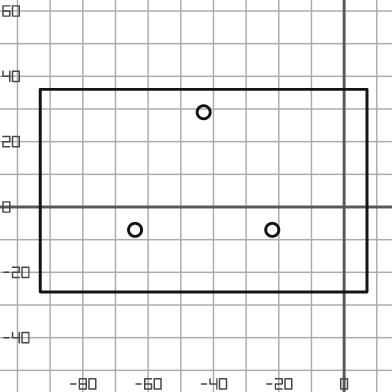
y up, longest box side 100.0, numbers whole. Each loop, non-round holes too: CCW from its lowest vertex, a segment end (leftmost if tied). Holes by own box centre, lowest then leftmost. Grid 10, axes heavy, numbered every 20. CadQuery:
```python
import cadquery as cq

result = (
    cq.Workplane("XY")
    .moveTo(-93.0, -26.0)
    .lineTo(7.0, -26.0)
    .lineTo(7.0, 36.0)
    .lineTo(-93.0, 36.0)
    .close()
    .moveTo(-64.0, -7.0)
    .circle(2.0)
    .moveTo(-22.0, -7.0)
    .circle(2.0)
    .moveTo(-43.0, 29.0)
    .circle(2.0)
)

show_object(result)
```